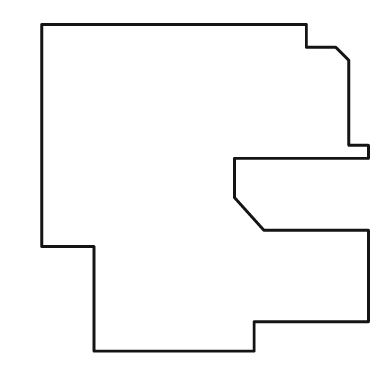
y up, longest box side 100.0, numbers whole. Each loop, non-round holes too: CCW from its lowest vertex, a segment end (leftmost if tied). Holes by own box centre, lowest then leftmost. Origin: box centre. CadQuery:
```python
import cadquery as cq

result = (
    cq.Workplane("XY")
    .moveTo(-34.0, -50.0)
    .lineTo(15.0, -50.0)
    .lineTo(15.0, -41.0)
    .lineTo(50.0, -41.0)
    .lineTo(50.0, -13.0)
    .lineTo(18.0, -13.0)
    .lineTo(9.0, -3.0)
    .lineTo(9.0, 9.0)
    .lineTo(50.0, 9.0)
    .lineTo(50.0, 13.0)
    .lineTo(44.0, 13.0)
    .lineTo(44.0, 39.0)
    .lineTo(40.0, 43.0)
    .lineTo(31.0, 43.0)
    .lineTo(31.0, 50.0)
    .lineTo(-50.0, 50.0)
    .lineTo(-50.0, -18.0)
    .lineTo(-34.0, -18.0)
    .close()
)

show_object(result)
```